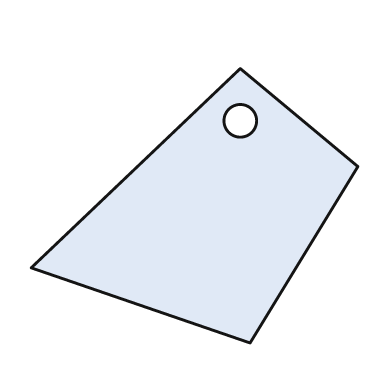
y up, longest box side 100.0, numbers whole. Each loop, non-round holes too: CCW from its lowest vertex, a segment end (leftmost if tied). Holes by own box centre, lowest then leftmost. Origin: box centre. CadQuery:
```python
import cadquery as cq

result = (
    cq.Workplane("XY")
    .moveTo(17.0, -42.0)
    .lineTo(50.0, 12.0)
    .lineTo(14.0, 42.0)
    .lineTo(-50.0, -19.0)
    .close()
    .moveTo(14.0, 26.0)
    .circle(5.0)
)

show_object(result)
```